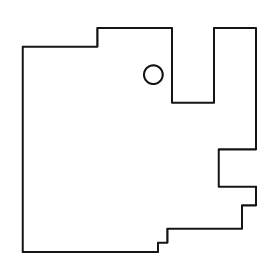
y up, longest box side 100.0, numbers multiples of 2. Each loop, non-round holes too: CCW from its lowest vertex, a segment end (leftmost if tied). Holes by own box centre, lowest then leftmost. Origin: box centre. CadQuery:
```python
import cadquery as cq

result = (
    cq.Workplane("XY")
    .moveTo(-50.0, -48.0)
    .lineTo(8.0, -48.0)
    .lineTo(8.0, -44.0)
    .lineTo(12.0, -44.0)
    .lineTo(12.0, -38.0)
    .lineTo(44.0, -38.0)
    .lineTo(44.0, -28.0)
    .lineTo(50.0, -28.0)
    .lineTo(50.0, -20.0)
    .lineTo(34.0, -20.0)
    .lineTo(34.0, -4.0)
    .lineTo(50.0, -4.0)
    .lineTo(50.0, 48.0)
    .lineTo(32.0, 48.0)
    .lineTo(32.0, 16.0)
    .lineTo(14.0, 16.0)
    .lineTo(14.0, 48.0)
    .lineTo(-18.0, 48.0)
    .lineTo(-18.0, 40.0)
    .lineTo(-50.0, 40.0)
    .close()
    .moveTo(6.0, 28.0)
    .circle(4.0)
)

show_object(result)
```